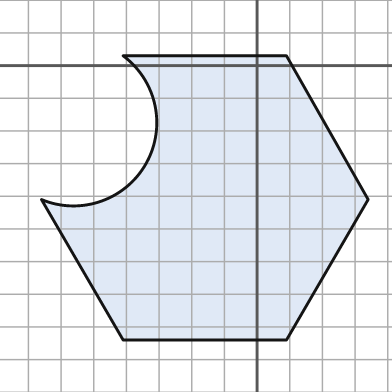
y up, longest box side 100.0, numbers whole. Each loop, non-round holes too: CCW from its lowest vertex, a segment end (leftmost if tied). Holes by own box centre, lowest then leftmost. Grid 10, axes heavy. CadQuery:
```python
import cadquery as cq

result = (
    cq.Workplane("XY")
    .moveTo(-41.0, -84.0)
    .lineTo(9.0, -84.0)
    .lineTo(34.0, -41.0)
    .lineTo(9.0, 3.0)
    .lineTo(-41.0, 3.0)
    .threePointArc((-34.0, -30.0), (-66.0, -41.0))
    .close()
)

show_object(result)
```